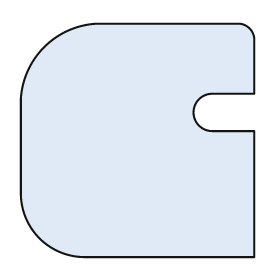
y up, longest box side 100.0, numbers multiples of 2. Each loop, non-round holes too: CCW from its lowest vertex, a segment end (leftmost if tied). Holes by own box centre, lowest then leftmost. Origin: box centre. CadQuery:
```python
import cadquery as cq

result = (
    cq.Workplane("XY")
    .moveTo(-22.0, -50.0)
    .lineTo(50.0, -50.0)
    .lineTo(50.0, 4.0)
    .lineTo(32.0, 4.0)
    .threePointArc((24.0, 12.0), (32.0, 20.0))
    .lineTo(50.0, 20.0)
    .lineTo(50.0, 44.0)
    .threePointArc((48.0, 48.0), (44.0, 50.0))
    .lineTo(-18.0, 50.0)
    .threePointArc((-40.0, 40.0), (-50.0, 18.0))
    .lineTo(-50.0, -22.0)
    .threePointArc((-42.0, -42.0), (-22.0, -50.0))
    .close()
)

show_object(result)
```